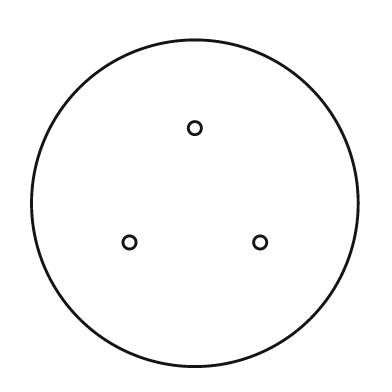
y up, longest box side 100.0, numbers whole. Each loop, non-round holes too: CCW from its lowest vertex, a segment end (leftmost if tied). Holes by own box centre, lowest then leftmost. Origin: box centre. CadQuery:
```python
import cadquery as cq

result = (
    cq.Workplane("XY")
    .moveTo(0.0, 0.0)
    .circle(50.0)
    .moveTo(-20.0, -12.0)
    .circle(2.0)
    .moveTo(20.0, -12.0)
    .circle(2.0)
    .moveTo(0.0, 23.0)
    .circle(2.0)
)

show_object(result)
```